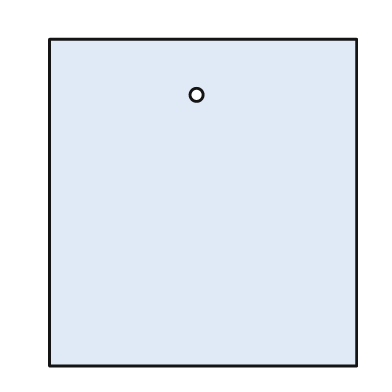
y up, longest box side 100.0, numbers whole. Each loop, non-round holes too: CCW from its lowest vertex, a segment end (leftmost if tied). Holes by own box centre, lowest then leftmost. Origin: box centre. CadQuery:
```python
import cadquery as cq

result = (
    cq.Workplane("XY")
    .moveTo(-47.0, -50.0)
    .lineTo(47.0, -50.0)
    .lineTo(47.0, 50.0)
    .lineTo(-47.0, 50.0)
    .close()
    .moveTo(-2.0, 33.0)
    .circle(2.0)
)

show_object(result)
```